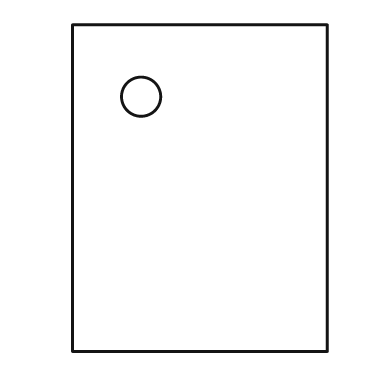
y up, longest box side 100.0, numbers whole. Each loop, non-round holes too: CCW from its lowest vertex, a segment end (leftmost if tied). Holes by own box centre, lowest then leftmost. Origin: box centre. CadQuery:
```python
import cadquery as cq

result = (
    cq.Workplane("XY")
    .moveTo(-39.0, -50.0)
    .lineTo(39.0, -50.0)
    .lineTo(39.0, 50.0)
    .lineTo(-39.0, 50.0)
    .close()
    .moveTo(-18.0, 28.0)
    .circle(6.0)
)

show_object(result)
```